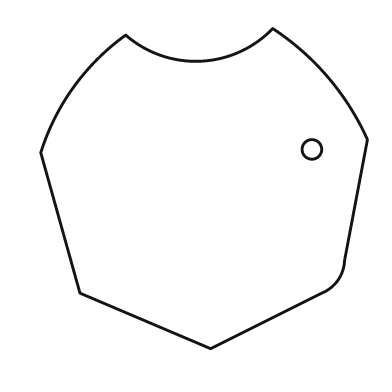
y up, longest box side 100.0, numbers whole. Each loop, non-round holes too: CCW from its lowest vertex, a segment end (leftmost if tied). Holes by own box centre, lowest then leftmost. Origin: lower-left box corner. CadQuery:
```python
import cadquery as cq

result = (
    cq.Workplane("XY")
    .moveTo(52.0, 0.0)
    .lineTo(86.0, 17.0)
    .threePointArc((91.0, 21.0), (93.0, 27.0))
    .lineTo(100.0, 64.0)
    .threePointArc((88.0, 83.0), (71.0, 98.0))
    .threePointArc((49.0, 88.0), (26.0, 96.0))
    .threePointArc((10.0, 80.0), (0.0, 60.0))
    .lineTo(12.0, 17.0)
    .close()
    .moveTo(83.0, 61.0)
    .circle(3.0)
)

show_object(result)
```